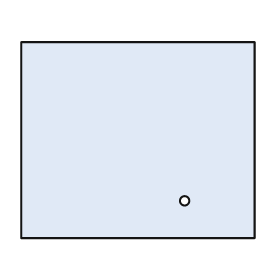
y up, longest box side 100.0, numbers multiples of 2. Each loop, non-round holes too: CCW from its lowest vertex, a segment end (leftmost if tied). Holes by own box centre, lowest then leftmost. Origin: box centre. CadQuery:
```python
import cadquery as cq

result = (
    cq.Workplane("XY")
    .moveTo(-50.0, -42.0)
    .lineTo(50.0, -42.0)
    .lineTo(50.0, 42.0)
    .lineTo(-50.0, 42.0)
    .close()
    .moveTo(20.0, -26.0)
    .circle(2.0)
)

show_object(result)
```